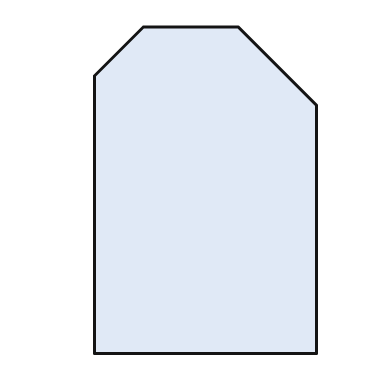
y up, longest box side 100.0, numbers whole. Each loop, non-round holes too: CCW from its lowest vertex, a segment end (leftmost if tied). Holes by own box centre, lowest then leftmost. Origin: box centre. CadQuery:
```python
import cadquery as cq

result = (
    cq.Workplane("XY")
    .moveTo(-34.0, -50.0)
    .lineTo(34.0, -50.0)
    .lineTo(34.0, 26.0)
    .lineTo(10.0, 50.0)
    .lineTo(-19.0, 50.0)
    .lineTo(-34.0, 35.0)
    .close()
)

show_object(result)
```